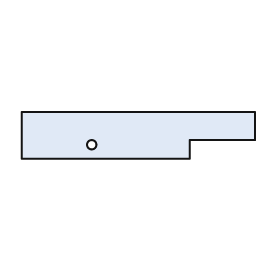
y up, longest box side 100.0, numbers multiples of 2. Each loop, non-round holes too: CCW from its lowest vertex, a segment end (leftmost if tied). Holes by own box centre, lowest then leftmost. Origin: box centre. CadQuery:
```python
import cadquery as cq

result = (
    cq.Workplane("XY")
    .moveTo(-50.0, -10.0)
    .lineTo(22.0, -10.0)
    .lineTo(22.0, -2.0)
    .lineTo(50.0, -2.0)
    .lineTo(50.0, 10.0)
    .lineTo(-50.0, 10.0)
    .close()
    .moveTo(-20.0, -4.0)
    .circle(2.0)
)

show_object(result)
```